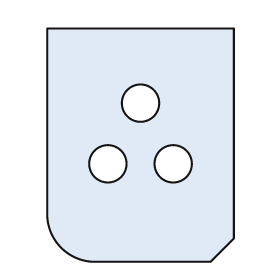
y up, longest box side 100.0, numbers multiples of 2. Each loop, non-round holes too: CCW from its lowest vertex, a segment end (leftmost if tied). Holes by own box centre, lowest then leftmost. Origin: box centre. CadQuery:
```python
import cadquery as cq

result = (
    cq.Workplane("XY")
    .moveTo(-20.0, -50.0)
    .lineTo(30.0, -50.0)
    .lineTo(40.0, -40.0)
    .lineTo(40.0, 50.0)
    .lineTo(-40.0, 50.0)
    .lineTo(-40.0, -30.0)
    .threePointArc((-34.0, -44.0), (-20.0, -50.0))
    .close()
    .moveTo(-14.0, -8.0)
    .circle(8.0)
    .moveTo(14.0, -8.0)
    .circle(8.0)
    .moveTo(0.0, 18.0)
    .circle(8.0)
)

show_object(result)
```